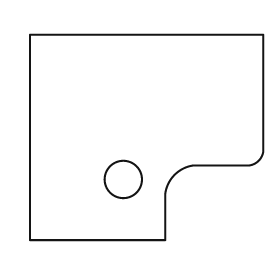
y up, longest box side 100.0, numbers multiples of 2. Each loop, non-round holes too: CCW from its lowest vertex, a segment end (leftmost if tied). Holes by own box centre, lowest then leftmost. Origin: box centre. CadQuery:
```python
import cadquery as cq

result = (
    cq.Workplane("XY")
    .moveTo(-50.0, -44.0)
    .lineTo(8.0, -44.0)
    .lineTo(8.0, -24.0)
    .threePointArc((12.0, -16.0), (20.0, -12.0))
    .lineTo(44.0, -12.0)
    .threePointArc((48.0, -10.0), (50.0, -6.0))
    .lineTo(50.0, 44.0)
    .lineTo(-50.0, 44.0)
    .close()
    .moveTo(-10.0, -18.0)
    .circle(8.0)
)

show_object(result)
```